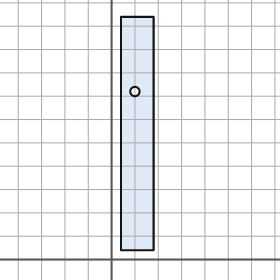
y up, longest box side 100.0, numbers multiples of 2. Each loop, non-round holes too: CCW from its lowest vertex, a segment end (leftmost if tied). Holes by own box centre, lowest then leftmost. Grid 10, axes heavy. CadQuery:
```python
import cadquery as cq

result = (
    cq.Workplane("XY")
    .moveTo(4.0, 4.0)
    .lineTo(18.0, 4.0)
    .lineTo(18.0, 104.0)
    .lineTo(4.0, 104.0)
    .close()
    .moveTo(10.0, 72.0)
    .circle(2.0)
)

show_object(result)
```